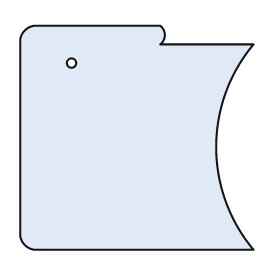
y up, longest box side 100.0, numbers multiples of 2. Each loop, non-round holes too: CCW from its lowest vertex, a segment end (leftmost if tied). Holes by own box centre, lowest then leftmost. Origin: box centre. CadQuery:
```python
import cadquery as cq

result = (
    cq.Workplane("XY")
    .moveTo(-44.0, -48.0)
    .lineTo(50.0, -48.0)
    .threePointArc((34.0, -4.0), (50.0, 40.0))
    .lineTo(10.0, 40.0)
    .threePointArc((12.0, 44.0), (10.0, 48.0))
    .lineTo(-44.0, 48.0)
    .threePointArc((-48.0, 46.0), (-50.0, 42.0))
    .lineTo(-50.0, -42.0)
    .threePointArc((-48.0, -46.0), (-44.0, -48.0))
    .close()
    .moveTo(-28.0, 32.0)
    .circle(2.0)
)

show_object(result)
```